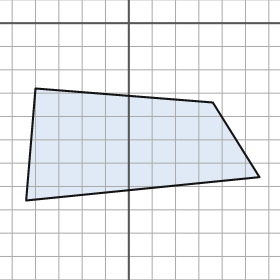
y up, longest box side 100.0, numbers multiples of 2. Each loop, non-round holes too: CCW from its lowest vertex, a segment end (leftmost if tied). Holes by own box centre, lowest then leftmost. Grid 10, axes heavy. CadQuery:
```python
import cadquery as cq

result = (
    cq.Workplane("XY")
    .moveTo(-44.0, -76.0)
    .lineTo(56.0, -66.0)
    .lineTo(36.0, -34.0)
    .lineTo(-40.0, -28.0)
    .close()
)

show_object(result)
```